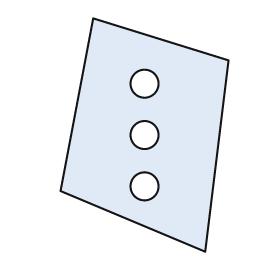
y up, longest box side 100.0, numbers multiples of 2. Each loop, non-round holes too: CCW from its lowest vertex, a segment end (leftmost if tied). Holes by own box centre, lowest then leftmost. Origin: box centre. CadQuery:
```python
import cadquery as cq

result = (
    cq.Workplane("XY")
    .moveTo(26.0, -50.0)
    .lineTo(36.0, 32.0)
    .lineTo(-22.0, 50.0)
    .lineTo(-36.0, -24.0)
    .close()
    .moveTo(0.0, -22.0)
    .circle(6.0)
    .moveTo(0.0, 0.0)
    .circle(6.0)
    .moveTo(0.0, 22.0)
    .circle(6.0)
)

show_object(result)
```